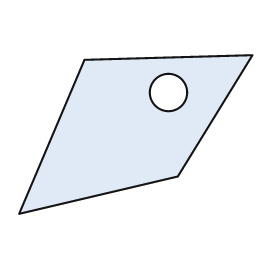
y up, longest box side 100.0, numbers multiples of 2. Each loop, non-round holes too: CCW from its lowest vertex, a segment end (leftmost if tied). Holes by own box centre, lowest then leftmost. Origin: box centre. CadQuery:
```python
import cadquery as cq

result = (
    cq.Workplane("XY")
    .moveTo(-50.0, -34.0)
    .lineTo(18.0, -18.0)
    .lineTo(50.0, 34.0)
    .lineTo(-22.0, 32.0)
    .close()
    .moveTo(14.0, 18.0)
    .circle(8.0)
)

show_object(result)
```